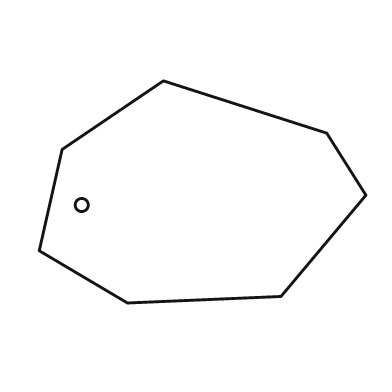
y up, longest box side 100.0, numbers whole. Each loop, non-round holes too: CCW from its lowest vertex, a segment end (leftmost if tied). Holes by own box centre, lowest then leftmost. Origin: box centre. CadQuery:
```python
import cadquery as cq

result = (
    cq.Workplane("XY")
    .moveTo(-23.0, -34.0)
    .lineTo(24.0, -32.0)
    .lineTo(50.0, -1.0)
    .lineTo(38.0, 18.0)
    .lineTo(-12.0, 34.0)
    .lineTo(-43.0, 13.0)
    .lineTo(-50.0, -18.0)
    .close()
    .moveTo(-37.0, -4.0)
    .circle(2.0)
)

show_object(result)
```